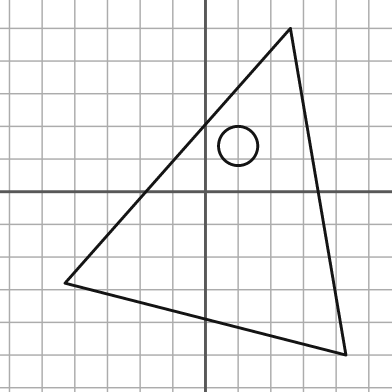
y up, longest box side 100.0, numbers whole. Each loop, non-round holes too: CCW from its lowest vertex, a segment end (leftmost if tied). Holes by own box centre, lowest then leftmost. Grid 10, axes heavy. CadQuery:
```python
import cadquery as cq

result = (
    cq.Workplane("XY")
    .moveTo(43.0, -50.0)
    .lineTo(26.0, 50.0)
    .lineTo(-43.0, -28.0)
    .close()
    .moveTo(10.0, 14.0)
    .circle(6.0)
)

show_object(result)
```